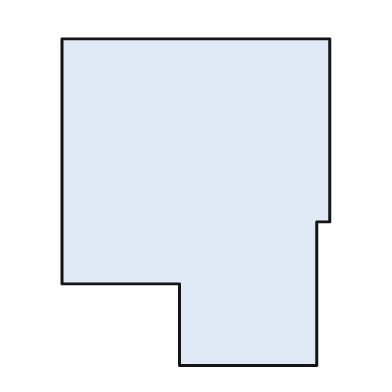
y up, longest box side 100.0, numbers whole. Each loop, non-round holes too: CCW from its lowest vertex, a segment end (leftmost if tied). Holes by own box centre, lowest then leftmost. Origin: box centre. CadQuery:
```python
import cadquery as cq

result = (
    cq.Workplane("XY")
    .moveTo(-5.0, -50.0)
    .lineTo(37.0, -50.0)
    .lineTo(37.0, -6.0)
    .lineTo(41.0, -6.0)
    .lineTo(41.0, 50.0)
    .lineTo(-41.0, 50.0)
    .lineTo(-41.0, -25.0)
    .lineTo(-5.0, -25.0)
    .close()
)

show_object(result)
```